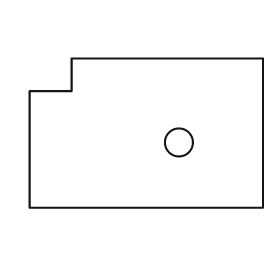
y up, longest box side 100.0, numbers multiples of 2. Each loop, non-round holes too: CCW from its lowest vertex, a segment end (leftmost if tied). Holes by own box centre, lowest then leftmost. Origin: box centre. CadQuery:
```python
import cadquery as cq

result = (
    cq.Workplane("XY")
    .moveTo(-50.0, -32.0)
    .lineTo(50.0, -32.0)
    .lineTo(50.0, 32.0)
    .lineTo(-32.0, 32.0)
    .lineTo(-32.0, 18.0)
    .lineTo(-50.0, 18.0)
    .close()
    .moveTo(14.0, -4.0)
    .circle(6.0)
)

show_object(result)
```